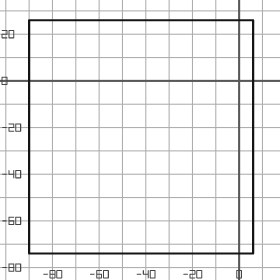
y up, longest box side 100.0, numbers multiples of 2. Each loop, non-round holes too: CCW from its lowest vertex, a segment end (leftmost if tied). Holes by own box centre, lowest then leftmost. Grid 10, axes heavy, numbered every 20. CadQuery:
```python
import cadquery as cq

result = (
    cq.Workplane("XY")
    .moveTo(-90.0, -74.0)
    .lineTo(6.0, -74.0)
    .lineTo(6.0, 26.0)
    .lineTo(-90.0, 26.0)
    .close()
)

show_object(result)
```